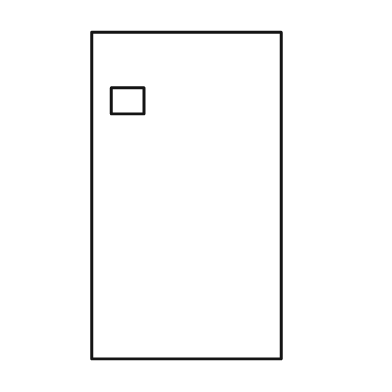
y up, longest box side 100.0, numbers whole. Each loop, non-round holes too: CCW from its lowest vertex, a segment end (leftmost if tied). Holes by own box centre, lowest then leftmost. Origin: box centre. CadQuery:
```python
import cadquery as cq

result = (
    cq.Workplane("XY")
    .moveTo(-29.0, -50.0)
    .lineTo(29.0, -50.0)
    .lineTo(29.0, 50.0)
    .lineTo(-29.0, 50.0)
    .close()
    .moveTo(-23.0, 25.0)
    .lineTo(-13.0, 25.0)
    .lineTo(-13.0, 33.0)
    .lineTo(-23.0, 33.0)
    .close()
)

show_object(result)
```